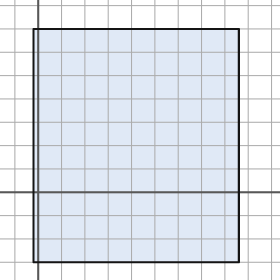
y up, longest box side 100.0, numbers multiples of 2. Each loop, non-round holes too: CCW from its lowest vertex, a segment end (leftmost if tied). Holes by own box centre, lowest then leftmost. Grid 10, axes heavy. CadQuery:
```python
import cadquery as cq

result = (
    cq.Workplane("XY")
    .moveTo(-2.0, -30.0)
    .lineTo(86.0, -30.0)
    .lineTo(86.0, 70.0)
    .lineTo(-2.0, 70.0)
    .close()
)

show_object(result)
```